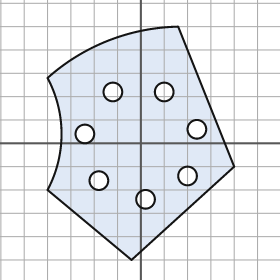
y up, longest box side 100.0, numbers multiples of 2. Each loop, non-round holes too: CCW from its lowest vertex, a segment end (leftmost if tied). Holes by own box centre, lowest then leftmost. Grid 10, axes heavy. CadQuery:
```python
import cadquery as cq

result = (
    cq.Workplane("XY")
    .moveTo(-4.0, -50.0)
    .lineTo(40.0, -10.0)
    .lineTo(16.0, 50.0)
    .threePointArc((-14.0, 44.0), (-40.0, 28.0))
    .threePointArc((-34.0, 4.0), (-40.0, -20.0))
    .close()
    .moveTo(2.0, -24.0)
    .circle(4.0)
    .moveTo(-18.0, -16.0)
    .circle(4.0)
    .moveTo(20.0, -14.0)
    .circle(4.0)
    .moveTo(-24.0, 4.0)
    .circle(4.0)
    .moveTo(24.0, 6.0)
    .circle(4.0)
    .moveTo(-12.0, 22.0)
    .circle(4.0)
    .moveTo(10.0, 22.0)
    .circle(4.0)
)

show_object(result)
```